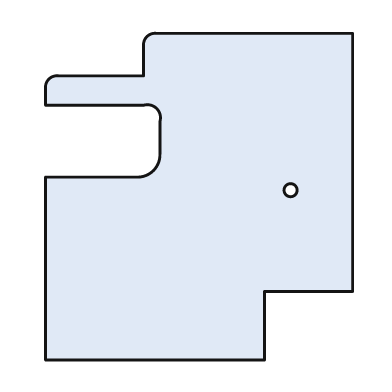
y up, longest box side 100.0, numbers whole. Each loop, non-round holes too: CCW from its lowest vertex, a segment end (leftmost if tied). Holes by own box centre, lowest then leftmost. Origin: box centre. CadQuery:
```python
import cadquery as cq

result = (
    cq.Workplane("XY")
    .moveTo(-47.0, -50.0)
    .lineTo(20.0, -50.0)
    .lineTo(20.0, -29.0)
    .lineTo(47.0, -29.0)
    .lineTo(47.0, 50.0)
    .lineTo(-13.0, 50.0)
    .threePointArc((-16.0, 49.0), (-17.0, 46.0))
    .lineTo(-17.0, 37.0)
    .lineTo(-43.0, 37.0)
    .threePointArc((-46.0, 36.0), (-47.0, 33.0))
    .lineTo(-47.0, 28.0)
    .lineTo(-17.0, 28.0)
    .threePointArc((-13.0, 27.0), (-12.0, 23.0))
    .lineTo(-12.0, 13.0)
    .threePointArc((-14.0, 8.0), (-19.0, 6.0))
    .lineTo(-47.0, 6.0)
    .close()
    .moveTo(28.0, 2.0)
    .circle(2.0)
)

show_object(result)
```